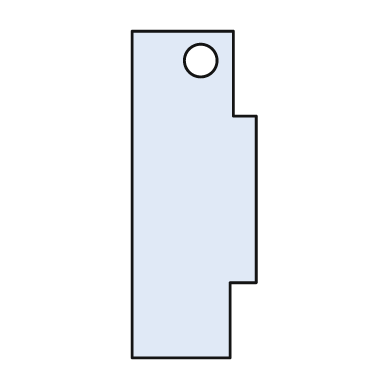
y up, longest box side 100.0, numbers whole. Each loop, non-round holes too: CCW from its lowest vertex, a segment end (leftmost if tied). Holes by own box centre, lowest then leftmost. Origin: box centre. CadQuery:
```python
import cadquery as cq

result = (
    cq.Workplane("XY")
    .moveTo(-19.0, -50.0)
    .lineTo(11.0, -50.0)
    .lineTo(11.0, -27.0)
    .lineTo(19.0, -27.0)
    .lineTo(19.0, 24.0)
    .lineTo(12.0, 24.0)
    .lineTo(12.0, 50.0)
    .lineTo(-19.0, 50.0)
    .close()
    .moveTo(2.0, 41.0)
    .circle(5.0)
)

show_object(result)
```